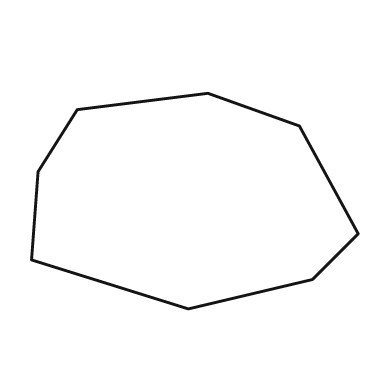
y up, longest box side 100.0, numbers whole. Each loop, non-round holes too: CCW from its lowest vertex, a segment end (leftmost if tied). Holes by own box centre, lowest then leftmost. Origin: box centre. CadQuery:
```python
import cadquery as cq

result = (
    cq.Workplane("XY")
    .moveTo(-2.0, -33.0)
    .lineTo(36.0, -24.0)
    .lineTo(50.0, -10.0)
    .lineTo(32.0, 23.0)
    .lineTo(4.0, 33.0)
    .lineTo(-36.0, 28.0)
    .lineTo(-48.0, 9.0)
    .lineTo(-50.0, -18.0)
    .close()
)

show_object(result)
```